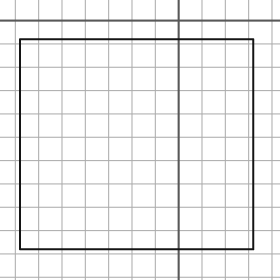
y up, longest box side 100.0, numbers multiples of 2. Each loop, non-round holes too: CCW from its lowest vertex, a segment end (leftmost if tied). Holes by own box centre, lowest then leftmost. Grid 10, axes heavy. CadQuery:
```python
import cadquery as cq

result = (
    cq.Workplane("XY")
    .moveTo(-68.0, -98.0)
    .lineTo(32.0, -98.0)
    .lineTo(32.0, -8.0)
    .lineTo(-68.0, -8.0)
    .close()
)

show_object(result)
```